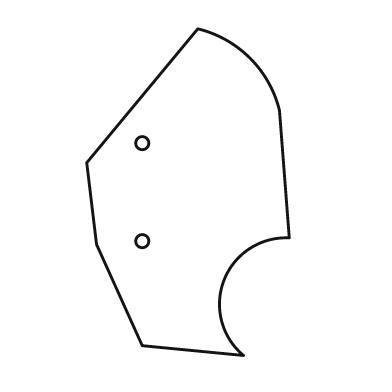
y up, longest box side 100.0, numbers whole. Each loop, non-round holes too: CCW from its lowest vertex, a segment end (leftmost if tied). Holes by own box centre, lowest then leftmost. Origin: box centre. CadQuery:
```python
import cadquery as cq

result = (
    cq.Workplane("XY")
    .moveTo(17.0, -50.0)
    .threePointArc((11.0, -27.0), (31.0, -14.0))
    .lineTo(28.0, 25.0)
    .threePointArc((19.0, 41.0), (3.0, 50.0))
    .lineTo(-31.0, 9.0)
    .lineTo(-28.0, -16.0)
    .lineTo(-14.0, -47.0)
    .close()
    .moveTo(-14.0, -15.0)
    .circle(2.0)
    .moveTo(-14.0, 15.0)
    .circle(2.0)
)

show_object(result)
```